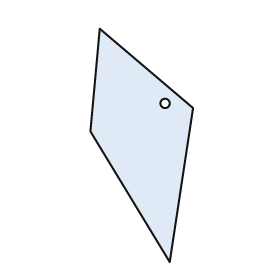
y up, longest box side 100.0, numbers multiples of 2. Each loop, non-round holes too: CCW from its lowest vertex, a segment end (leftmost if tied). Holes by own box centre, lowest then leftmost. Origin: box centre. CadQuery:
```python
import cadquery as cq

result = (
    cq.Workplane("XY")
    .moveTo(12.0, -50.0)
    .lineTo(22.0, 16.0)
    .lineTo(-18.0, 50.0)
    .lineTo(-22.0, 6.0)
    .close()
    .moveTo(10.0, 18.0)
    .circle(2.0)
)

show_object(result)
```